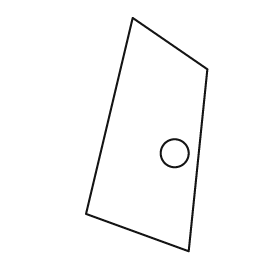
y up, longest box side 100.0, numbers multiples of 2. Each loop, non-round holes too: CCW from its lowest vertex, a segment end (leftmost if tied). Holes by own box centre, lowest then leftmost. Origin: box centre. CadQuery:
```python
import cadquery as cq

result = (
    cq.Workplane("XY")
    .moveTo(18.0, -50.0)
    .lineTo(26.0, 28.0)
    .lineTo(-6.0, 50.0)
    .lineTo(-26.0, -34.0)
    .close()
    .moveTo(12.0, -8.0)
    .circle(6.0)
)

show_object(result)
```